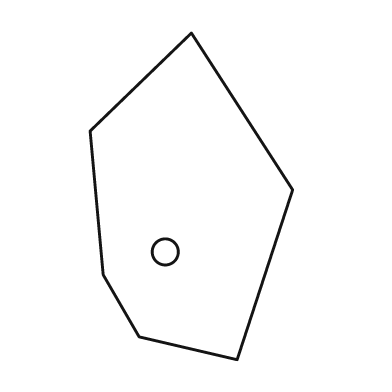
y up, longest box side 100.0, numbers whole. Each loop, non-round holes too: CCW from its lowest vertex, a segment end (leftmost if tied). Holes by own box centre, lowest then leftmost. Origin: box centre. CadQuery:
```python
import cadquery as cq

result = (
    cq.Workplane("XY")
    .moveTo(14.0, -50.0)
    .lineTo(31.0, 2.0)
    .lineTo(0.0, 50.0)
    .lineTo(-31.0, 20.0)
    .lineTo(-27.0, -24.0)
    .lineTo(-16.0, -43.0)
    .close()
    .moveTo(-8.0, -17.0)
    .circle(4.0)
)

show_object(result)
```